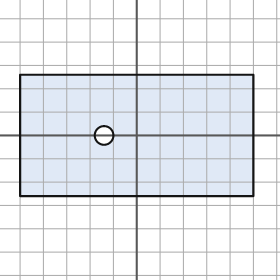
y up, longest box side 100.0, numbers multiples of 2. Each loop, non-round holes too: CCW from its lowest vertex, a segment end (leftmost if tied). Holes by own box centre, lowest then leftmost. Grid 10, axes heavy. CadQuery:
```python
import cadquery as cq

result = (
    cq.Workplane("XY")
    .moveTo(-50.0, -26.0)
    .lineTo(50.0, -26.0)
    .lineTo(50.0, 26.0)
    .lineTo(-50.0, 26.0)
    .close()
    .moveTo(-14.0, 0.0)
    .circle(4.0)
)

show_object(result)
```